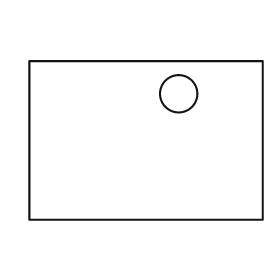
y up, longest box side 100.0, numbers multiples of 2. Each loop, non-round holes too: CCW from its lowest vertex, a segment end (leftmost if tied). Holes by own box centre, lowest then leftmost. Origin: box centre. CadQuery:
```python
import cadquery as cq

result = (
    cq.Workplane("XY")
    .moveTo(-50.0, -34.0)
    .lineTo(50.0, -34.0)
    .lineTo(50.0, 34.0)
    .lineTo(-50.0, 34.0)
    .close()
    .moveTo(14.0, 20.0)
    .circle(8.0)
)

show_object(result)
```